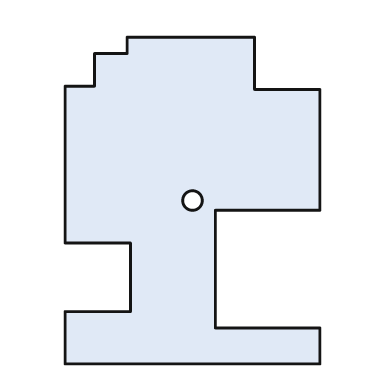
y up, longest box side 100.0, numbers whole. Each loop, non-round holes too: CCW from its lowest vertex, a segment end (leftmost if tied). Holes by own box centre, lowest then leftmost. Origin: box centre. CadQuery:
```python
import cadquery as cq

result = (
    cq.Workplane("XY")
    .moveTo(-39.0, -50.0)
    .lineTo(39.0, -50.0)
    .lineTo(39.0, -39.0)
    .lineTo(7.0, -39.0)
    .lineTo(7.0, -3.0)
    .lineTo(39.0, -3.0)
    .lineTo(39.0, 34.0)
    .lineTo(19.0, 34.0)
    .lineTo(19.0, 50.0)
    .lineTo(-20.0, 50.0)
    .lineTo(-20.0, 45.0)
    .lineTo(-30.0, 45.0)
    .lineTo(-30.0, 35.0)
    .lineTo(-39.0, 35.0)
    .lineTo(-39.0, -13.0)
    .lineTo(-19.0, -13.0)
    .lineTo(-19.0, -34.0)
    .lineTo(-39.0, -34.0)
    .close()
    .moveTo(0.0, 0.0)
    .circle(3.0)
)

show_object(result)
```